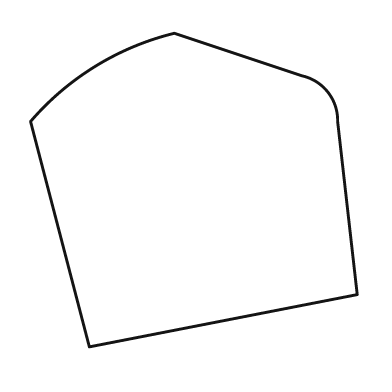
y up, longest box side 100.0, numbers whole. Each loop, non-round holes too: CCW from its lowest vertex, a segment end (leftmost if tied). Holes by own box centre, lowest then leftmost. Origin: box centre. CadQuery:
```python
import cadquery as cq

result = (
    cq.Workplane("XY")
    .moveTo(-32.0, -48.0)
    .lineTo(50.0, -32.0)
    .lineTo(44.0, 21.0)
    .threePointArc((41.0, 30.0), (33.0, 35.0))
    .lineTo(-6.0, 48.0)
    .threePointArc((-30.0, 38.0), (-50.0, 21.0))
    .close()
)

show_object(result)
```